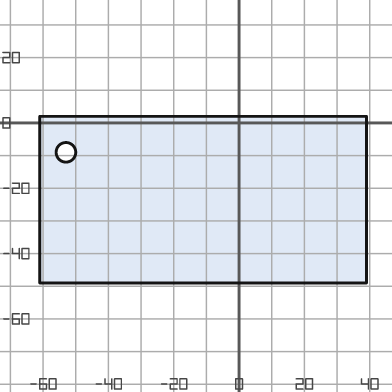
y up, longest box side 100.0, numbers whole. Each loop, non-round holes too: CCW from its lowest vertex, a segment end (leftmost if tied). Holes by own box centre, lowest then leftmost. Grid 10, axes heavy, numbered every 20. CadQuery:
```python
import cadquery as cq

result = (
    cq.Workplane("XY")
    .moveTo(-61.0, -49.0)
    .lineTo(39.0, -49.0)
    .lineTo(39.0, 2.0)
    .lineTo(-61.0, 2.0)
    .close()
    .moveTo(-53.0, -9.0)
    .circle(3.0)
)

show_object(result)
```